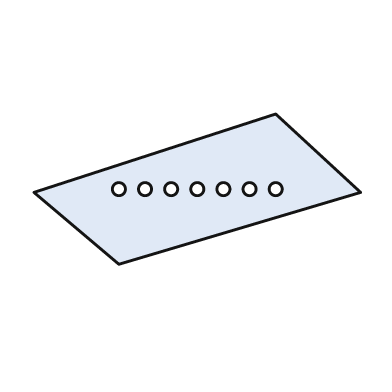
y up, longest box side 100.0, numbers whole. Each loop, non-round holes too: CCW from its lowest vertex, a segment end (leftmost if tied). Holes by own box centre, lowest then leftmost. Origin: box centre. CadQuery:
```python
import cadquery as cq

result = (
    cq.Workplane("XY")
    .moveTo(-24.0, -23.0)
    .lineTo(50.0, -1.0)
    .lineTo(24.0, 23.0)
    .lineTo(-50.0, -1.0)
    .close()
    .moveTo(-24.0, 0.0)
    .circle(2.0)
    .moveTo(-16.0, 0.0)
    .circle(2.0)
    .moveTo(-8.0, 0.0)
    .circle(2.0)
    .moveTo(0.0, 0.0)
    .circle(2.0)
    .moveTo(8.0, 0.0)
    .circle(2.0)
    .moveTo(16.0, 0.0)
    .circle(2.0)
    .moveTo(24.0, 0.0)
    .circle(2.0)
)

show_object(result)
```